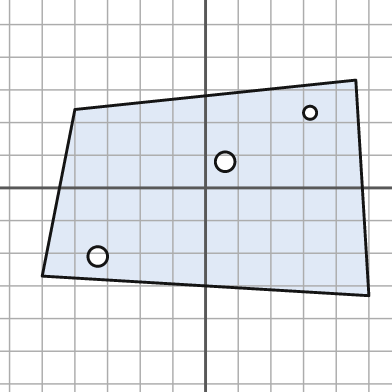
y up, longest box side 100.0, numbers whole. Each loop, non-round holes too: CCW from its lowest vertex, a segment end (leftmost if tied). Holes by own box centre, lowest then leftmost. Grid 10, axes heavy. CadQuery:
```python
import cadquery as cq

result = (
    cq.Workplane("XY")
    .moveTo(50.0, -33.0)
    .lineTo(46.0, 33.0)
    .lineTo(-40.0, 24.0)
    .lineTo(-50.0, -27.0)
    .close()
    .moveTo(-33.0, -21.0)
    .circle(3.0)
    .moveTo(6.0, 8.0)
    .circle(3.0)
    .moveTo(32.0, 23.0)
    .circle(2.0)
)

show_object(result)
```